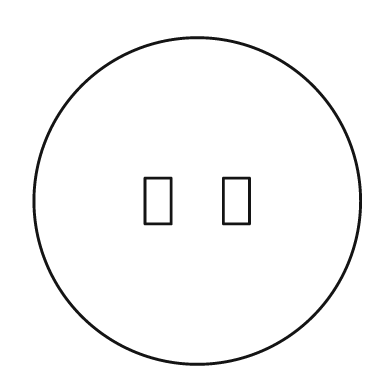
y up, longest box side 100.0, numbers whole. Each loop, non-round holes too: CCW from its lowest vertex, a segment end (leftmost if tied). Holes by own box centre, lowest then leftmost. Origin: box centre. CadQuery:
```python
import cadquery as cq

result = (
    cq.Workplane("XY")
    .moveTo(0.0, 0.0)
    .circle(50.0)
    .moveTo(-16.0, -7.0)
    .lineTo(-8.0, -7.0)
    .lineTo(-8.0, 7.0)
    .lineTo(-16.0, 7.0)
    .close()
    .moveTo(8.0, -7.0)
    .lineTo(16.0, -7.0)
    .lineTo(16.0, 7.0)
    .lineTo(8.0, 7.0)
    .close()
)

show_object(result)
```